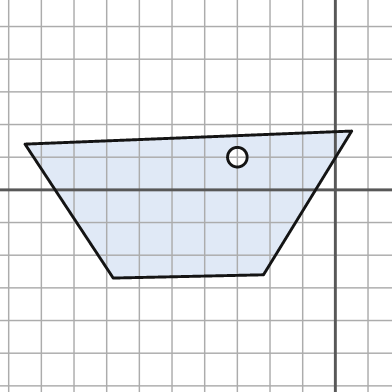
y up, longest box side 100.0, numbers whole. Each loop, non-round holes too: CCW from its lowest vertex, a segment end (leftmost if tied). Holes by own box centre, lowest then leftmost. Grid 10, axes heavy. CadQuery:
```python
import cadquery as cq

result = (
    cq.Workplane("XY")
    .moveTo(-68.0, -27.0)
    .lineTo(-22.0, -26.0)
    .lineTo(5.0, 18.0)
    .lineTo(-95.0, 14.0)
    .close()
    .moveTo(-30.0, 10.0)
    .circle(3.0)
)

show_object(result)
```